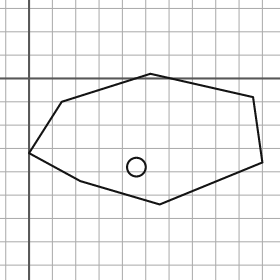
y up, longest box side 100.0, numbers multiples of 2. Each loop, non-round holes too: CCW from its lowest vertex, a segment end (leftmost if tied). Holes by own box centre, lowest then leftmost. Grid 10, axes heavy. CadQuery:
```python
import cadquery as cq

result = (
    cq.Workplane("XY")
    .moveTo(56.0, -54.0)
    .lineTo(100.0, -36.0)
    .lineTo(96.0, -8.0)
    .lineTo(52.0, 2.0)
    .lineTo(14.0, -10.0)
    .lineTo(0.0, -32.0)
    .lineTo(22.0, -44.0)
    .close()
    .moveTo(46.0, -38.0)
    .circle(4.0)
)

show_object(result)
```